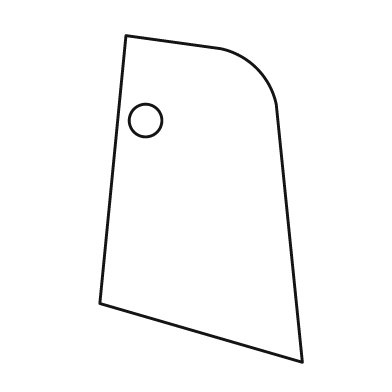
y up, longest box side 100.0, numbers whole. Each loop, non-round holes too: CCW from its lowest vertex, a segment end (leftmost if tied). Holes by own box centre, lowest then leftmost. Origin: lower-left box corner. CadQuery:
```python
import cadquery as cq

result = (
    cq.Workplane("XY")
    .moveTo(62.0, 0.0)
    .lineTo(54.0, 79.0)
    .threePointArc((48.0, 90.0), (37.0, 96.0))
    .lineTo(8.0, 100.0)
    .lineTo(0.0, 18.0)
    .close()
    .moveTo(14.0, 74.0)
    .circle(5.0)
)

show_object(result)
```